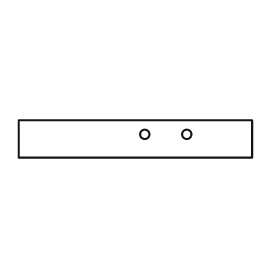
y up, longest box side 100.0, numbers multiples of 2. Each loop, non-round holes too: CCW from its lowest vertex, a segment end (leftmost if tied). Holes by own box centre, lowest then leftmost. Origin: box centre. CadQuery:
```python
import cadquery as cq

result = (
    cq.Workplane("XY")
    .moveTo(-50.0, -8.0)
    .lineTo(50.0, -8.0)
    .lineTo(50.0, 8.0)
    .lineTo(-50.0, 8.0)
    .close()
    .moveTo(4.0, 2.0)
    .circle(2.0)
    .moveTo(22.0, 2.0)
    .circle(2.0)
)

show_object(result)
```